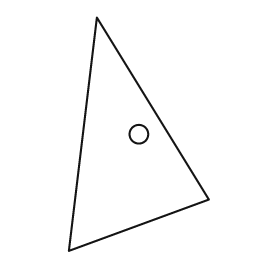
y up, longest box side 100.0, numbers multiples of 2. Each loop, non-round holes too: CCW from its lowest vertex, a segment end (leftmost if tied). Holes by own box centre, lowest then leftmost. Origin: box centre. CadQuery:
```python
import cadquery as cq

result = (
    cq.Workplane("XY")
    .moveTo(-30.0, -50.0)
    .lineTo(30.0, -28.0)
    .lineTo(-18.0, 50.0)
    .close()
    .moveTo(0.0, 0.0)
    .circle(4.0)
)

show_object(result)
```